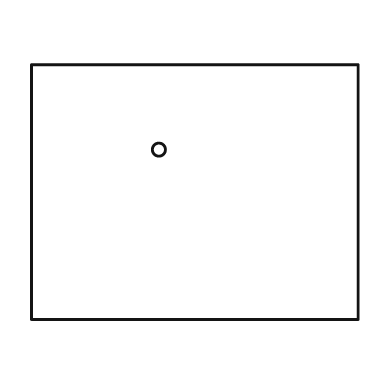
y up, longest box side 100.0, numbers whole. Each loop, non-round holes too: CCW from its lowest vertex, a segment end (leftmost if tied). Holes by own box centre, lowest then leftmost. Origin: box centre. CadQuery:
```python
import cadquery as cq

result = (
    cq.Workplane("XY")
    .moveTo(-50.0, -39.0)
    .lineTo(50.0, -39.0)
    .lineTo(50.0, 39.0)
    .lineTo(-50.0, 39.0)
    .close()
    .moveTo(-11.0, 13.0)
    .circle(2.0)
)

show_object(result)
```